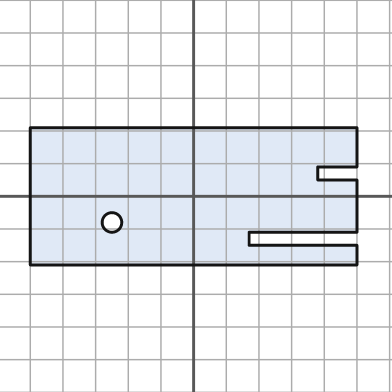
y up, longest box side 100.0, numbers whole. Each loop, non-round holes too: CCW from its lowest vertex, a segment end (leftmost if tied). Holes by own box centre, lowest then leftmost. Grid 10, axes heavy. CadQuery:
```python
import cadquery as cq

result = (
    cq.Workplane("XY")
    .moveTo(-50.0, -21.0)
    .lineTo(50.0, -21.0)
    .lineTo(50.0, -15.0)
    .lineTo(17.0, -15.0)
    .lineTo(17.0, -11.0)
    .lineTo(50.0, -11.0)
    .lineTo(50.0, 5.0)
    .lineTo(38.0, 5.0)
    .lineTo(38.0, 9.0)
    .lineTo(50.0, 9.0)
    .lineTo(50.0, 21.0)
    .lineTo(-50.0, 21.0)
    .close()
    .moveTo(-25.0, -8.0)
    .circle(3.0)
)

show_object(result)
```